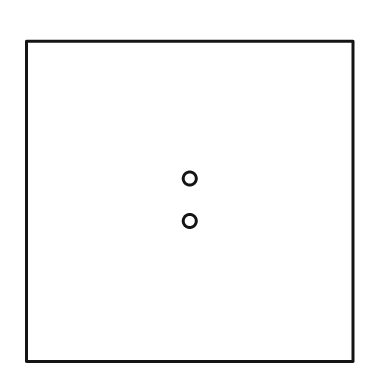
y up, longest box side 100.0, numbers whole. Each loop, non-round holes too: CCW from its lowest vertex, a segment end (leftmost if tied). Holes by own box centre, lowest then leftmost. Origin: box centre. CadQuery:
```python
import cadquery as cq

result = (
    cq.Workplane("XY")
    .moveTo(-50.0, -49.0)
    .lineTo(50.0, -49.0)
    .lineTo(50.0, 49.0)
    .lineTo(-50.0, 49.0)
    .close()
    .moveTo(0.0, -6.0)
    .circle(2.0)
    .moveTo(0.0, 7.0)
    .circle(2.0)
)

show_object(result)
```